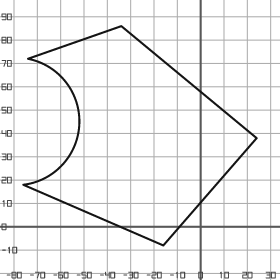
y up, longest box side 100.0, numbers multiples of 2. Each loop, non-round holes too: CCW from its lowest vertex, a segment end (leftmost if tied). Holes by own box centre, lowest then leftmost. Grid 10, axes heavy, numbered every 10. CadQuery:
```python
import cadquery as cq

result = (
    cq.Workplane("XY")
    .moveTo(-16.0, -8.0)
    .lineTo(24.0, 38.0)
    .lineTo(-34.0, 86.0)
    .lineTo(-74.0, 72.0)
    .threePointArc((-52.0, 44.0), (-76.0, 18.0))
    .close()
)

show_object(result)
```